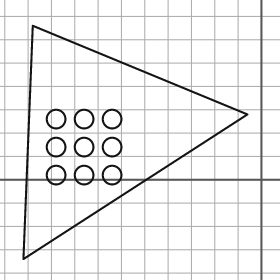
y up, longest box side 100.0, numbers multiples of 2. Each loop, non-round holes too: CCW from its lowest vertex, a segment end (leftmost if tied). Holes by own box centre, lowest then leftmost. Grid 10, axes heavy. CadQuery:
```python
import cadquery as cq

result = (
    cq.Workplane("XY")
    .moveTo(-102.0, -34.0)
    .lineTo(-6.0, 28.0)
    .lineTo(-98.0, 66.0)
    .close()
    .moveTo(-88.0, 2.0)
    .circle(4.0)
    .moveTo(-76.0, 2.0)
    .circle(4.0)
    .moveTo(-64.0, 2.0)
    .circle(4.0)
    .moveTo(-88.0, 14.0)
    .circle(4.0)
    .moveTo(-76.0, 14.0)
    .circle(4.0)
    .moveTo(-64.0, 14.0)
    .circle(4.0)
    .moveTo(-88.0, 26.0)
    .circle(4.0)
    .moveTo(-76.0, 26.0)
    .circle(4.0)
    .moveTo(-64.0, 26.0)
    .circle(4.0)
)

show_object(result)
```